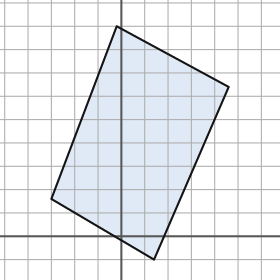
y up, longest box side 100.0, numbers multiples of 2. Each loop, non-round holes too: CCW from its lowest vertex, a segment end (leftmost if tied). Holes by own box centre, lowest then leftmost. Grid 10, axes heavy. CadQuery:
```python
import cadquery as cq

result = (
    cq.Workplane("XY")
    .moveTo(14.0, -10.0)
    .lineTo(46.0, 64.0)
    .lineTo(-2.0, 90.0)
    .lineTo(-30.0, 16.0)
    .close()
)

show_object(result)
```